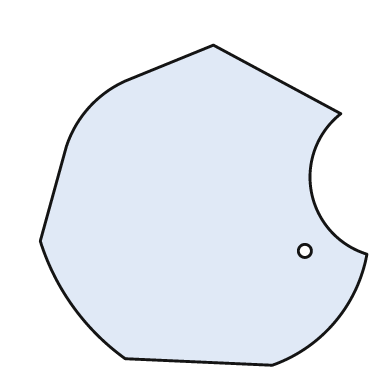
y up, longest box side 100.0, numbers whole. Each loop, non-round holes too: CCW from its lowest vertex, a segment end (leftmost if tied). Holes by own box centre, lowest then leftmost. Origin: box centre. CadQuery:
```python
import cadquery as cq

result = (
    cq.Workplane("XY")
    .moveTo(21.0, -49.0)
    .threePointArc((40.0, -36.0), (50.0, -15.0))
    .threePointArc((33.0, 4.0), (42.0, 28.0))
    .lineTo(3.0, 49.0)
    .lineTo(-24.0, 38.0)
    .threePointArc((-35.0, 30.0), (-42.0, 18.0))
    .lineTo(-50.0, -11.0)
    .threePointArc((-40.0, -31.0), (-24.0, -47.0))
    .close()
    .moveTo(31.0, -14.0)
    .circle(2.0)
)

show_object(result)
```